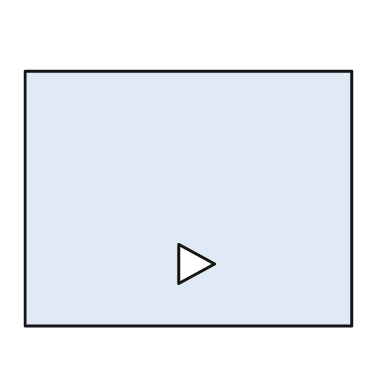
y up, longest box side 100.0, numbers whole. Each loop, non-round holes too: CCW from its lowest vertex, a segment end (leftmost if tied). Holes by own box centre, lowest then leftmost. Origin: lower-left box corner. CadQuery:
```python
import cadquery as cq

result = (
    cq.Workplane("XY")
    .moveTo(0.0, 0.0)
    .lineTo(100.0, 0.0)
    .lineTo(100.0, 78.0)
    .lineTo(0.0, 78.0)
    .close()
    .moveTo(47.0, 13.0)
    .lineTo(58.0, 19.0)
    .lineTo(47.0, 25.0)
    .close()
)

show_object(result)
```